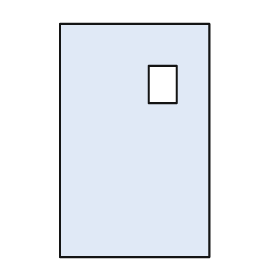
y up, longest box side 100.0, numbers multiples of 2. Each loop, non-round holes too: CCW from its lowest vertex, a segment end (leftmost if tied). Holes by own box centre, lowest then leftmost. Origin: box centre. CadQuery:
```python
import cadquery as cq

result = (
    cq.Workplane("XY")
    .moveTo(-32.0, -50.0)
    .lineTo(32.0, -50.0)
    .lineTo(32.0, 50.0)
    .lineTo(-32.0, 50.0)
    .close()
    .moveTo(6.0, 16.0)
    .lineTo(18.0, 16.0)
    .lineTo(18.0, 32.0)
    .lineTo(6.0, 32.0)
    .close()
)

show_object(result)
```